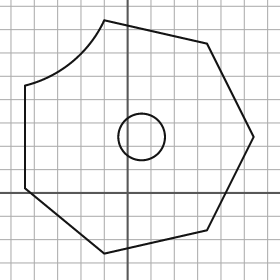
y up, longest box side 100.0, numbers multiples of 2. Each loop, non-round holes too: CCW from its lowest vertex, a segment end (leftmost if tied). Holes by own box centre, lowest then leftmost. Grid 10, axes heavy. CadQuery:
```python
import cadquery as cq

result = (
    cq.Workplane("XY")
    .moveTo(-10.0, -26.0)
    .lineTo(34.0, -16.0)
    .lineTo(54.0, 24.0)
    .lineTo(34.0, 64.0)
    .lineTo(-10.0, 74.0)
    .threePointArc((-24.0, 56.0), (-44.0, 46.0))
    .lineTo(-44.0, 2.0)
    .close()
    .moveTo(6.0, 24.0)
    .circle(10.0)
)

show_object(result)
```